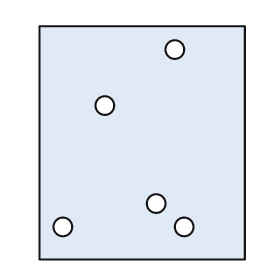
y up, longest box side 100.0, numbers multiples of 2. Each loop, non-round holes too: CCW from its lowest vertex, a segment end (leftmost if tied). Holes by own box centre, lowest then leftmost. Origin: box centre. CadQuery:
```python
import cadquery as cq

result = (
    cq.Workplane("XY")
    .moveTo(-44.0, -50.0)
    .lineTo(44.0, -50.0)
    .lineTo(44.0, 50.0)
    .lineTo(-44.0, 50.0)
    .close()
    .moveTo(-34.0, -36.0)
    .circle(4.0)
    .moveTo(18.0, -36.0)
    .circle(4.0)
    .moveTo(6.0, -26.0)
    .circle(4.0)
    .moveTo(-16.0, 16.0)
    .circle(4.0)
    .moveTo(14.0, 40.0)
    .circle(4.0)
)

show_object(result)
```